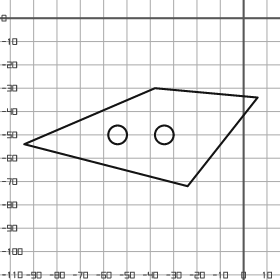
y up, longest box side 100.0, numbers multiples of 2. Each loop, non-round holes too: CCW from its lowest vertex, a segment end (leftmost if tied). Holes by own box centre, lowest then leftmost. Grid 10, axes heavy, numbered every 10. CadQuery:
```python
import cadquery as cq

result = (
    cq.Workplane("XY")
    .moveTo(-24.0, -72.0)
    .lineTo(6.0, -34.0)
    .lineTo(-38.0, -30.0)
    .lineTo(-94.0, -54.0)
    .close()
    .moveTo(-54.0, -50.0)
    .circle(4.0)
    .moveTo(-34.0, -50.0)
    .circle(4.0)
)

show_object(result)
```